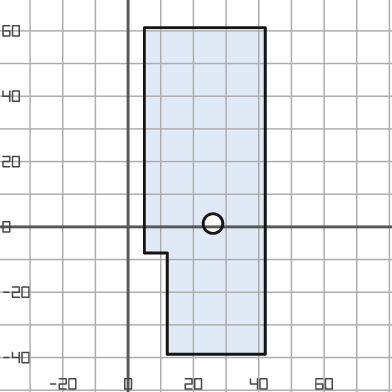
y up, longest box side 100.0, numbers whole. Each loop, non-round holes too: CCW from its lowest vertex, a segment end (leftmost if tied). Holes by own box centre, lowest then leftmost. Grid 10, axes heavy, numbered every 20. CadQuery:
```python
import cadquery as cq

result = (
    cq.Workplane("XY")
    .moveTo(12.0, -39.0)
    .lineTo(42.0, -39.0)
    .lineTo(42.0, 61.0)
    .lineTo(5.0, 61.0)
    .lineTo(5.0, -8.0)
    .lineTo(12.0, -8.0)
    .close()
    .moveTo(26.0, 1.0)
    .circle(3.0)
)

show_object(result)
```